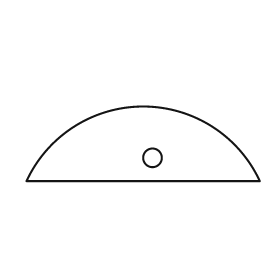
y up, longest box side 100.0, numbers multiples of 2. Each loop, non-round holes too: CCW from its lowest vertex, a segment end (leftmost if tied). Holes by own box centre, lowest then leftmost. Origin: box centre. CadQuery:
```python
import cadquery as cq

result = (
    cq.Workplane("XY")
    .moveTo(-50.0, -16.0)
    .lineTo(50.0, -16.0)
    .threePointArc((0.0, 16.0), (-50.0, -16.0))
    .close()
    .moveTo(4.0, -6.0)
    .circle(4.0)
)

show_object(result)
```